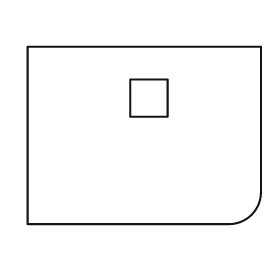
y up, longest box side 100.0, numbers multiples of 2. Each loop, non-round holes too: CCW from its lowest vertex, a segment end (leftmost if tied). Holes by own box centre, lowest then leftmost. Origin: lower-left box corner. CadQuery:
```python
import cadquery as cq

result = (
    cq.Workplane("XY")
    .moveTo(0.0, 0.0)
    .lineTo(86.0, 0.0)
    .threePointArc((96.0, 4.0), (100.0, 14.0))
    .lineTo(100.0, 76.0)
    .lineTo(0.0, 76.0)
    .close()
    .moveTo(44.0, 46.0)
    .lineTo(60.0, 46.0)
    .lineTo(60.0, 62.0)
    .lineTo(44.0, 62.0)
    .close()
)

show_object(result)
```